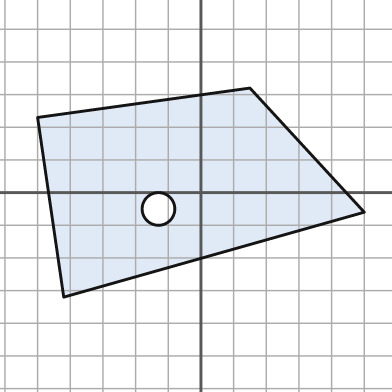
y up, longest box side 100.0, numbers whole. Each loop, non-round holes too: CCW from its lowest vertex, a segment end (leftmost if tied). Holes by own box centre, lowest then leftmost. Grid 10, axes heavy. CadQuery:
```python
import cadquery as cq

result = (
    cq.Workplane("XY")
    .moveTo(-42.0, -32.0)
    .lineTo(50.0, -6.0)
    .lineTo(15.0, 32.0)
    .lineTo(-50.0, 23.0)
    .close()
    .moveTo(-13.0, -5.0)
    .circle(5.0)
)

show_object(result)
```